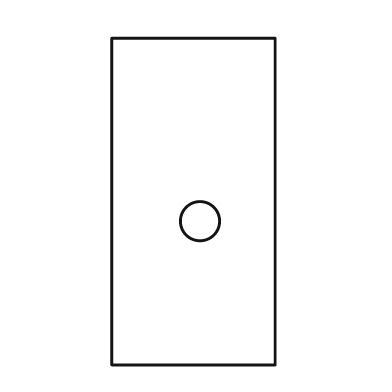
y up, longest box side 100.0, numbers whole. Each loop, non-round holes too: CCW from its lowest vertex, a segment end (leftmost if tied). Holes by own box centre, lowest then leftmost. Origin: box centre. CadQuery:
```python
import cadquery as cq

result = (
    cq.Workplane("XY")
    .moveTo(-25.0, -50.0)
    .lineTo(25.0, -50.0)
    .lineTo(25.0, 50.0)
    .lineTo(-25.0, 50.0)
    .close()
    .moveTo(2.0, -6.0)
    .circle(6.0)
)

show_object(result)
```